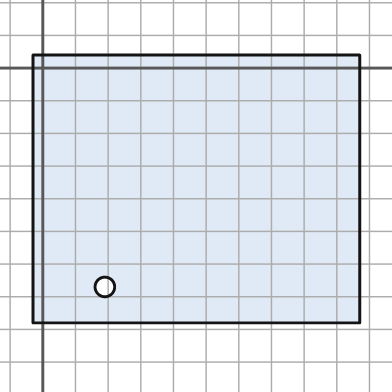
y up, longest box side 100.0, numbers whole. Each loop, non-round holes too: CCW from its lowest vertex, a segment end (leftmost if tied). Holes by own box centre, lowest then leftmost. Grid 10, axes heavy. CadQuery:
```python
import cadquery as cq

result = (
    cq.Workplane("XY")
    .moveTo(-3.0, -78.0)
    .lineTo(97.0, -78.0)
    .lineTo(97.0, 4.0)
    .lineTo(-3.0, 4.0)
    .close()
    .moveTo(19.0, -67.0)
    .circle(3.0)
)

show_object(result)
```